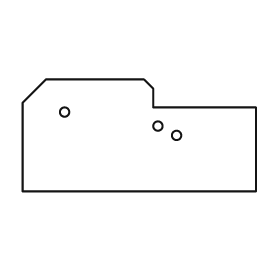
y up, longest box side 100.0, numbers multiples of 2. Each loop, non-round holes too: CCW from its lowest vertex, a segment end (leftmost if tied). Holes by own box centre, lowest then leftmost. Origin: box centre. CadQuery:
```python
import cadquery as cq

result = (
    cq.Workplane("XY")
    .moveTo(-50.0, -24.0)
    .lineTo(50.0, -24.0)
    .lineTo(50.0, 12.0)
    .lineTo(6.0, 12.0)
    .lineTo(6.0, 20.0)
    .lineTo(2.0, 24.0)
    .lineTo(-40.0, 24.0)
    .lineTo(-50.0, 14.0)
    .close()
    .moveTo(16.0, 0.0)
    .circle(2.0)
    .moveTo(8.0, 4.0)
    .circle(2.0)
    .moveTo(-32.0, 10.0)
    .circle(2.0)
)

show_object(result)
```